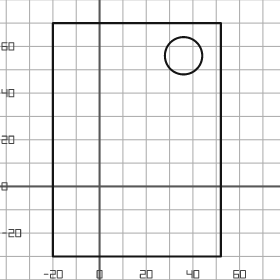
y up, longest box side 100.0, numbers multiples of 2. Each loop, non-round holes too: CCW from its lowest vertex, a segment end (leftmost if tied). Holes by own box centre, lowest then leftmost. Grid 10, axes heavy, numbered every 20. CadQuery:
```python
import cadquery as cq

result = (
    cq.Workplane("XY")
    .moveTo(-20.0, -30.0)
    .lineTo(52.0, -30.0)
    .lineTo(52.0, 70.0)
    .lineTo(-20.0, 70.0)
    .close()
    .moveTo(36.0, 56.0)
    .circle(8.0)
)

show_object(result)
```